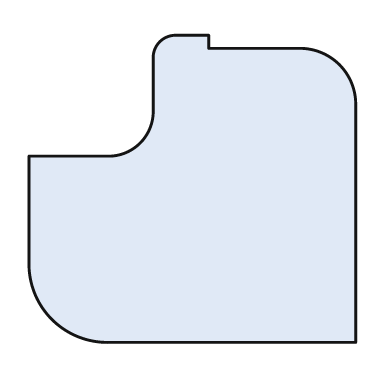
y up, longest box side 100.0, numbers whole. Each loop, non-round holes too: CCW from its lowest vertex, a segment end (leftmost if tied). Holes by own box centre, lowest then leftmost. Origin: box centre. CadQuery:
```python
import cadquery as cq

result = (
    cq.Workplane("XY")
    .moveTo(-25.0, -47.0)
    .lineTo(50.0, -47.0)
    .lineTo(50.0, 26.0)
    .threePointArc((45.0, 38.0), (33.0, 43.0))
    .lineTo(5.0, 43.0)
    .lineTo(5.0, 47.0)
    .lineTo(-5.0, 47.0)
    .threePointArc((-10.0, 45.0), (-12.0, 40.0))
    .lineTo(-12.0, 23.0)
    .threePointArc((-16.0, 14.0), (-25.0, 10.0))
    .lineTo(-50.0, 10.0)
    .lineTo(-50.0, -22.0)
    .threePointArc((-43.0, -40.0), (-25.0, -47.0))
    .close()
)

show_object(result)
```